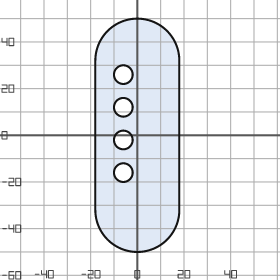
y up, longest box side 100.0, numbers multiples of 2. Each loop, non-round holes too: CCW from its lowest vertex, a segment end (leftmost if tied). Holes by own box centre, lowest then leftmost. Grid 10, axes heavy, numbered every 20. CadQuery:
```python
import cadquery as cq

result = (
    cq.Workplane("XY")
    .moveTo(-18.0, -32.0)
    .threePointArc((0.0, -50.0), (18.0, -32.0))
    .lineTo(18.0, 32.0)
    .threePointArc((0.0, 50.0), (-18.0, 32.0))
    .close()
    .moveTo(-6.0, -16.0)
    .circle(4.0)
    .moveTo(-6.0, -2.0)
    .circle(4.0)
    .moveTo(-6.0, 12.0)
    .circle(4.0)
    .moveTo(-6.0, 26.0)
    .circle(4.0)
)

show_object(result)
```